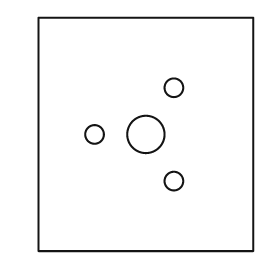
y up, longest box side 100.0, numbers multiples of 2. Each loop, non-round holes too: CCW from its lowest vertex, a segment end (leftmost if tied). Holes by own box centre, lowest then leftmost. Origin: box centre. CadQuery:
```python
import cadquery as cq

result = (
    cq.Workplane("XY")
    .moveTo(-46.0, -50.0)
    .lineTo(46.0, -50.0)
    .lineTo(46.0, 50.0)
    .lineTo(-46.0, 50.0)
    .close()
    .moveTo(12.0, -20.0)
    .circle(4.0)
    .moveTo(-22.0, 0.0)
    .circle(4.0)
    .moveTo(0.0, 0.0)
    .circle(8.0)
    .moveTo(12.0, 20.0)
    .circle(4.0)
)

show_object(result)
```